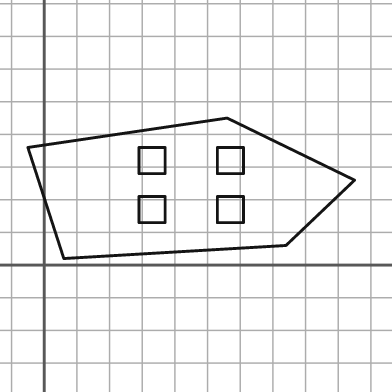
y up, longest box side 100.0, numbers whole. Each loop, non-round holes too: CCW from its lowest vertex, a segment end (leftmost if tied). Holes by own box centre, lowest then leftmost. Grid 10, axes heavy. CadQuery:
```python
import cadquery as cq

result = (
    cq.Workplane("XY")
    .moveTo(6.0, 2.0)
    .lineTo(74.0, 6.0)
    .lineTo(95.0, 26.0)
    .lineTo(56.0, 45.0)
    .lineTo(-5.0, 36.0)
    .close()
    .moveTo(29.0, 13.0)
    .lineTo(37.0, 13.0)
    .lineTo(37.0, 21.0)
    .lineTo(29.0, 21.0)
    .close()
    .moveTo(53.0, 13.0)
    .lineTo(61.0, 13.0)
    .lineTo(61.0, 21.0)
    .lineTo(53.0, 21.0)
    .close()
    .moveTo(29.0, 28.0)
    .lineTo(37.0, 28.0)
    .lineTo(37.0, 36.0)
    .lineTo(29.0, 36.0)
    .close()
    .moveTo(53.0, 28.0)
    .lineTo(61.0, 28.0)
    .lineTo(61.0, 36.0)
    .lineTo(53.0, 36.0)
    .close()
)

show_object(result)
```